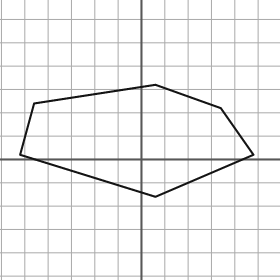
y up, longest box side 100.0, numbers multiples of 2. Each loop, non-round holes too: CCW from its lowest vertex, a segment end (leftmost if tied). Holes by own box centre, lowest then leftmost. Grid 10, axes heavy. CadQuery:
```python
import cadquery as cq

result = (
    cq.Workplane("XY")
    .moveTo(6.0, -16.0)
    .lineTo(48.0, 2.0)
    .lineTo(34.0, 22.0)
    .lineTo(6.0, 32.0)
    .lineTo(-46.0, 24.0)
    .lineTo(-52.0, 2.0)
    .close()
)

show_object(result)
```